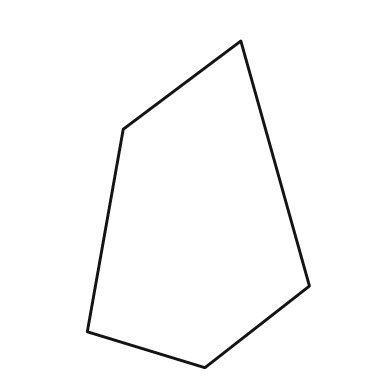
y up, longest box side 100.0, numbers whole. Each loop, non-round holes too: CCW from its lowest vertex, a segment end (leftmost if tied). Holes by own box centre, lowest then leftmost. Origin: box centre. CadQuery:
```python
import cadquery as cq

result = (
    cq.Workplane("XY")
    .moveTo(2.0, -50.0)
    .lineTo(34.0, -25.0)
    .lineTo(13.0, 50.0)
    .lineTo(-23.0, 23.0)
    .lineTo(-34.0, -39.0)
    .close()
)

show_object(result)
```